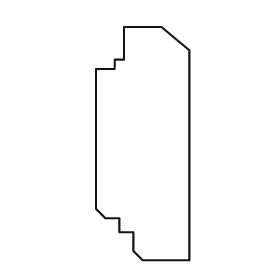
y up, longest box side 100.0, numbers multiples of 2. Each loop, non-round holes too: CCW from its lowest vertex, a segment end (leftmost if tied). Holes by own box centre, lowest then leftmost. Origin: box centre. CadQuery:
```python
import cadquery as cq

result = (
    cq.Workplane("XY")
    .moveTo(0.0, -50.0)
    .lineTo(20.0, -50.0)
    .lineTo(20.0, 40.0)
    .lineTo(8.0, 50.0)
    .lineTo(-8.0, 50.0)
    .lineTo(-8.0, 36.0)
    .lineTo(-12.0, 36.0)
    .lineTo(-12.0, 32.0)
    .lineTo(-20.0, 32.0)
    .lineTo(-20.0, -28.0)
    .lineTo(-16.0, -32.0)
    .lineTo(-10.0, -32.0)
    .lineTo(-10.0, -38.0)
    .lineTo(-4.0, -38.0)
    .lineTo(-4.0, -46.0)
    .close()
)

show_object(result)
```